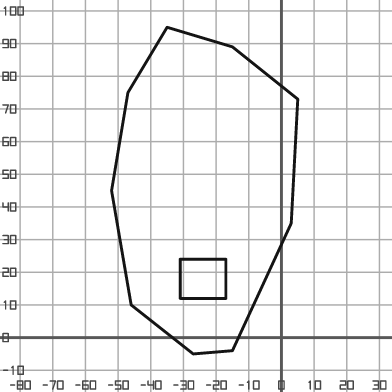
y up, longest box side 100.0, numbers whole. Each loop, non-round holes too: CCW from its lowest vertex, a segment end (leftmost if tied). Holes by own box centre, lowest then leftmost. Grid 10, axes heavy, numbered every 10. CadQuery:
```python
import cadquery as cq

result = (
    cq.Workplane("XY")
    .moveTo(-27.0, -5.0)
    .lineTo(-15.0, -4.0)
    .lineTo(3.0, 35.0)
    .lineTo(5.0, 73.0)
    .lineTo(-15.0, 89.0)
    .lineTo(-35.0, 95.0)
    .lineTo(-47.0, 75.0)
    .lineTo(-52.0, 45.0)
    .lineTo(-46.0, 10.0)
    .close()
    .moveTo(-31.0, 12.0)
    .lineTo(-17.0, 12.0)
    .lineTo(-17.0, 24.0)
    .lineTo(-31.0, 24.0)
    .close()
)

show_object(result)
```